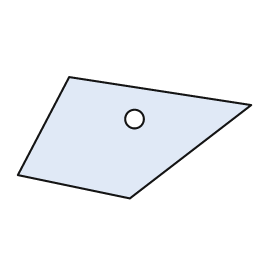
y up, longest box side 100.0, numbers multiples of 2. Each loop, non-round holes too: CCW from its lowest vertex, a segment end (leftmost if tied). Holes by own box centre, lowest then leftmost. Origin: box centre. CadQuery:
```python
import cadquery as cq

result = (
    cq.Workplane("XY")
    .moveTo(-2.0, -26.0)
    .lineTo(50.0, 14.0)
    .lineTo(-28.0, 26.0)
    .lineTo(-50.0, -16.0)
    .close()
    .moveTo(0.0, 8.0)
    .circle(4.0)
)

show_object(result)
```